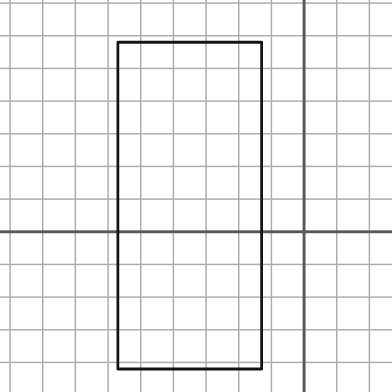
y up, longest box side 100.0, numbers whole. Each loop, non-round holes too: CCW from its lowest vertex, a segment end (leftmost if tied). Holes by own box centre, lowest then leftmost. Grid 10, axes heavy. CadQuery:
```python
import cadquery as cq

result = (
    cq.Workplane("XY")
    .moveTo(-57.0, -42.0)
    .lineTo(-13.0, -42.0)
    .lineTo(-13.0, 58.0)
    .lineTo(-57.0, 58.0)
    .close()
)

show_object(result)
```